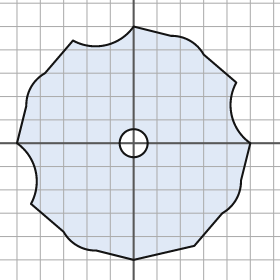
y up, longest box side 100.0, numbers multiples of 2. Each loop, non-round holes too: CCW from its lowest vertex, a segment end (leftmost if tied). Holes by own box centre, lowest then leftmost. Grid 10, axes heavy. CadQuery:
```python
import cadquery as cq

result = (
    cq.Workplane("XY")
    .moveTo(0.0, -50.0)
    .lineTo(26.0, -44.0)
    .lineTo(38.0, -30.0)
    .threePointArc((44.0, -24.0), (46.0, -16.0))
    .lineTo(50.0, 0.0)
    .threePointArc((42.0, 12.0), (44.0, 26.0))
    .lineTo(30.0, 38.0)
    .threePointArc((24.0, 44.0), (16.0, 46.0))
    .lineTo(0.0, 50.0)
    .threePointArc((-12.0, 42.0), (-26.0, 44.0))
    .lineTo(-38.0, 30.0)
    .threePointArc((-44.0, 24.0), (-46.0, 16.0))
    .lineTo(-50.0, 0.0)
    .threePointArc((-42.0, -12.0), (-44.0, -26.0))
    .lineTo(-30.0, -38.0)
    .threePointArc((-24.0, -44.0), (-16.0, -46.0))
    .close()
    .moveTo(0.0, 0.0)
    .circle(6.0)
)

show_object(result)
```